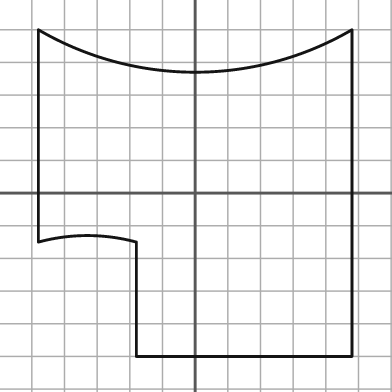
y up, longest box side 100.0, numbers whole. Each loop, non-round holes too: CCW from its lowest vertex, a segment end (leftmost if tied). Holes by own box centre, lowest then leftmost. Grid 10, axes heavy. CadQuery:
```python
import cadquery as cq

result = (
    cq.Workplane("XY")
    .moveTo(-18.0, -50.0)
    .lineTo(48.0, -50.0)
    .lineTo(48.0, 50.0)
    .threePointArc((0.0, 37.0), (-48.0, 50.0))
    .lineTo(-48.0, -15.0)
    .threePointArc((-33.0, -13.0), (-18.0, -15.0))
    .close()
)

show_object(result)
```